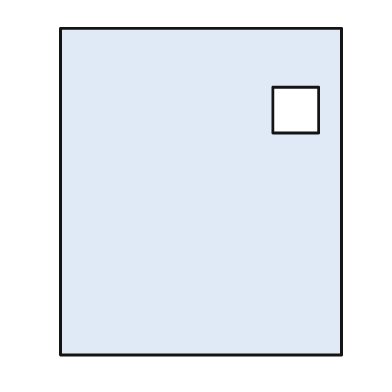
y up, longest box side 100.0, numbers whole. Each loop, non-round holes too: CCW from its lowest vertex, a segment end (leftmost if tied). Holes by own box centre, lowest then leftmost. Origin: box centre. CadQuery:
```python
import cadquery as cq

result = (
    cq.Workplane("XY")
    .moveTo(-43.0, -50.0)
    .lineTo(43.0, -50.0)
    .lineTo(43.0, 50.0)
    .lineTo(-43.0, 50.0)
    .close()
    .moveTo(22.0, 18.0)
    .lineTo(36.0, 18.0)
    .lineTo(36.0, 32.0)
    .lineTo(22.0, 32.0)
    .close()
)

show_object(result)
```